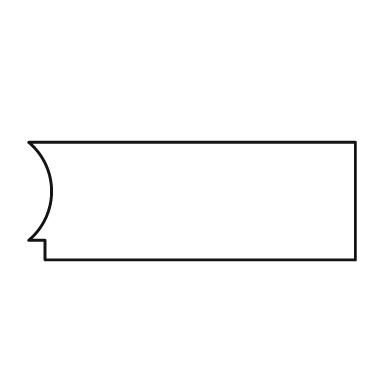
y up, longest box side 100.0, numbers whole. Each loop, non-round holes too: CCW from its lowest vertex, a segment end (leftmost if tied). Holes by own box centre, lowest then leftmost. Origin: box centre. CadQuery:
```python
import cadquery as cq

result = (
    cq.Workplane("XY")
    .moveTo(-45.0, -18.0)
    .lineTo(50.0, -18.0)
    .lineTo(50.0, 18.0)
    .lineTo(-50.0, 18.0)
    .threePointArc((-43.0, 3.0), (-50.0, -12.0))
    .lineTo(-45.0, -12.0)
    .close()
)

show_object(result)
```